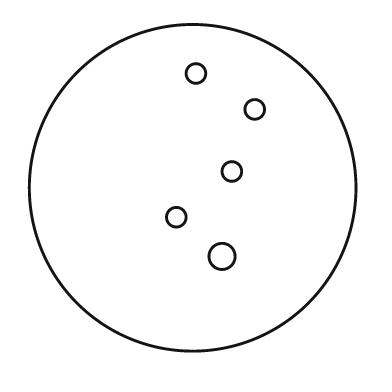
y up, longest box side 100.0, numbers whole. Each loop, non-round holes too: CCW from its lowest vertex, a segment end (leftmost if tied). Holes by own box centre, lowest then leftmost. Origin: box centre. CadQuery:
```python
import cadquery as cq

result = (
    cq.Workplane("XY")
    .moveTo(0.0, 0.0)
    .circle(50.0)
    .moveTo(9.0, -21.0)
    .circle(4.0)
    .moveTo(-5.0, -9.0)
    .circle(3.0)
    .moveTo(12.0, 5.0)
    .circle(3.0)
    .moveTo(19.0, 24.0)
    .circle(3.0)
    .moveTo(1.0, 35.0)
    .circle(3.0)
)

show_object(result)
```